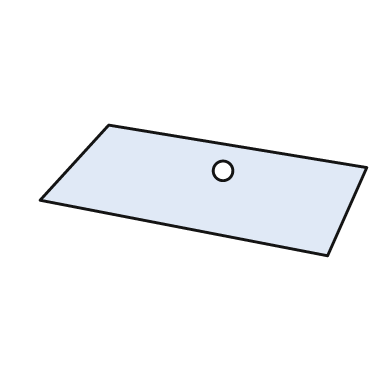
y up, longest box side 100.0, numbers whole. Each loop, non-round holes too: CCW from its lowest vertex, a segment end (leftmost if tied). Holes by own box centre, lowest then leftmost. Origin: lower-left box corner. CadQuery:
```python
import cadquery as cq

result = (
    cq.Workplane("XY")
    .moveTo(88.0, 0.0)
    .lineTo(100.0, 27.0)
    .lineTo(21.0, 40.0)
    .lineTo(0.0, 17.0)
    .close()
    .moveTo(56.0, 26.0)
    .circle(3.0)
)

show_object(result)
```